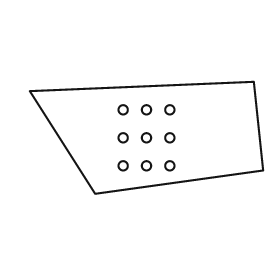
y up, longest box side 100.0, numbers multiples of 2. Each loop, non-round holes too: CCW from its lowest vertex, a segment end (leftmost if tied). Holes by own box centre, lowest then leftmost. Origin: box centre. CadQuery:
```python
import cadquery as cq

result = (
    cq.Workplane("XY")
    .moveTo(-22.0, -24.0)
    .lineTo(50.0, -14.0)
    .lineTo(46.0, 24.0)
    .lineTo(-50.0, 20.0)
    .close()
    .moveTo(-10.0, -12.0)
    .circle(2.0)
    .moveTo(0.0, -12.0)
    .circle(2.0)
    .moveTo(10.0, -12.0)
    .circle(2.0)
    .moveTo(-10.0, 0.0)
    .circle(2.0)
    .moveTo(0.0, 0.0)
    .circle(2.0)
    .moveTo(10.0, 0.0)
    .circle(2.0)
    .moveTo(-10.0, 12.0)
    .circle(2.0)
    .moveTo(0.0, 12.0)
    .circle(2.0)
    .moveTo(10.0, 12.0)
    .circle(2.0)
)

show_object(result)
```